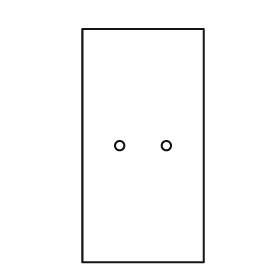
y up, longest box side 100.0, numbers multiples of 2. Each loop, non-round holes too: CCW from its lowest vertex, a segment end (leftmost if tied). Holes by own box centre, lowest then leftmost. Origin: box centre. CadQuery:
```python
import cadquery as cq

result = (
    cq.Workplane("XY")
    .moveTo(-26.0, -50.0)
    .lineTo(26.0, -50.0)
    .lineTo(26.0, 50.0)
    .lineTo(-26.0, 50.0)
    .close()
    .moveTo(-10.0, 0.0)
    .circle(2.0)
    .moveTo(10.0, 0.0)
    .circle(2.0)
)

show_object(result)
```